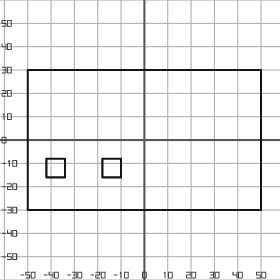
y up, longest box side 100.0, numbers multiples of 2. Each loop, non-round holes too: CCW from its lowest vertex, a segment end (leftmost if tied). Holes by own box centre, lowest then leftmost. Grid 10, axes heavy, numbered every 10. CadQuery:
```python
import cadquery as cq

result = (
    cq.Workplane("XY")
    .moveTo(-50.0, -30.0)
    .lineTo(50.0, -30.0)
    .lineTo(50.0, 30.0)
    .lineTo(-50.0, 30.0)
    .close()
    .moveTo(-42.0, -16.0)
    .lineTo(-34.0, -16.0)
    .lineTo(-34.0, -8.0)
    .lineTo(-42.0, -8.0)
    .close()
    .moveTo(-18.0, -16.0)
    .lineTo(-10.0, -16.0)
    .lineTo(-10.0, -8.0)
    .lineTo(-18.0, -8.0)
    .close()
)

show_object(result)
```